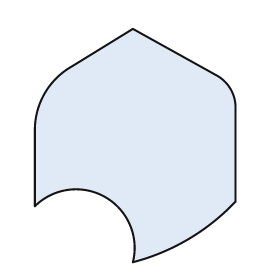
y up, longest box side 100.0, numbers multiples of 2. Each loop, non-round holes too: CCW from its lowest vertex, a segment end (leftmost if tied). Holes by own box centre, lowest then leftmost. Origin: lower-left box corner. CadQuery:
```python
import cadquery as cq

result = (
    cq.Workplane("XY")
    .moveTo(42.0, 0.0)
    .threePointArc((66.0, 10.0), (86.0, 26.0))
    .lineTo(86.0, 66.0)
    .threePointArc((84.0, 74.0), (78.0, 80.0))
    .lineTo(42.0, 100.0)
    .lineTo(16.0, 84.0)
    .threePointArc((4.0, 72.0), (0.0, 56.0))
    .lineTo(0.0, 24.0)
    .threePointArc((30.0, 28.0), (42.0, 0.0))
    .close()
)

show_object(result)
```